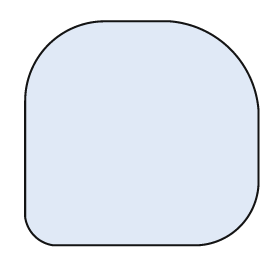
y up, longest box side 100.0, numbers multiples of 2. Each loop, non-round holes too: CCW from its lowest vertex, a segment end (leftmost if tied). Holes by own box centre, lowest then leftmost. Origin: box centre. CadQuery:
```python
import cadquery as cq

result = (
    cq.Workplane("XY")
    .moveTo(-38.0, -48.0)
    .lineTo(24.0, -48.0)
    .threePointArc((42.0, -40.0), (50.0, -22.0))
    .lineTo(50.0, 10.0)
    .threePointArc((38.0, 36.0), (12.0, 48.0))
    .lineTo(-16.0, 48.0)
    .threePointArc((-40.0, 38.0), (-50.0, 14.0))
    .lineTo(-50.0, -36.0)
    .threePointArc((-46.0, -44.0), (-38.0, -48.0))
    .close()
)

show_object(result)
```